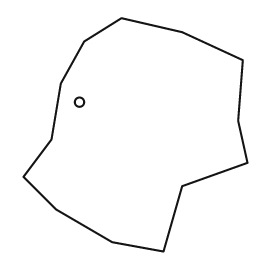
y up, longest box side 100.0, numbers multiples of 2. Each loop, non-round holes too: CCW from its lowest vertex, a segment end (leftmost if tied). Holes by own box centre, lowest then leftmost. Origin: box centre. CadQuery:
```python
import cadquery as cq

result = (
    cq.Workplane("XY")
    .moveTo(12.0, -50.0)
    .lineTo(20.0, -22.0)
    .lineTo(48.0, -12.0)
    .lineTo(44.0, 6.0)
    .lineTo(46.0, 32.0)
    .lineTo(20.0, 44.0)
    .lineTo(-6.0, 50.0)
    .lineTo(-22.0, 40.0)
    .lineTo(-32.0, 22.0)
    .lineTo(-36.0, -2.0)
    .lineTo(-48.0, -18.0)
    .lineTo(-34.0, -32.0)
    .lineTo(-10.0, -46.0)
    .close()
    .moveTo(-24.0, 14.0)
    .circle(2.0)
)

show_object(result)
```